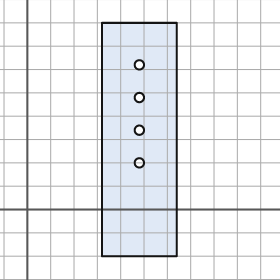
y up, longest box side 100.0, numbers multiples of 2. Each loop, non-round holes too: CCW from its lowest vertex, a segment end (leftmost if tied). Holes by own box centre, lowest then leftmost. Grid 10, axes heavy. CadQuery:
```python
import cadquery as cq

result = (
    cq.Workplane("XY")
    .moveTo(32.0, -20.0)
    .lineTo(64.0, -20.0)
    .lineTo(64.0, 80.0)
    .lineTo(32.0, 80.0)
    .close()
    .moveTo(48.0, 20.0)
    .circle(2.0)
    .moveTo(48.0, 34.0)
    .circle(2.0)
    .moveTo(48.0, 48.0)
    .circle(2.0)
    .moveTo(48.0, 62.0)
    .circle(2.0)
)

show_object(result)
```